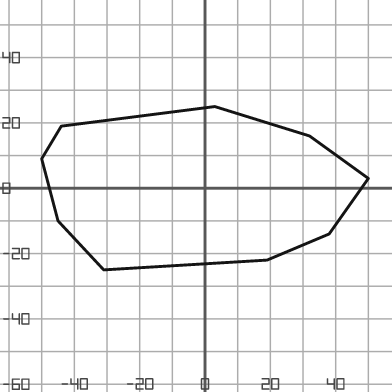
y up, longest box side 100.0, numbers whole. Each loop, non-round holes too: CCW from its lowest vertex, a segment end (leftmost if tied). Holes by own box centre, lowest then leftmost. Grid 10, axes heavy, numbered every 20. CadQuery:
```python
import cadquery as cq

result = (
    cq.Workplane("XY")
    .moveTo(-31.0, -25.0)
    .lineTo(19.0, -22.0)
    .lineTo(38.0, -14.0)
    .lineTo(50.0, 3.0)
    .lineTo(32.0, 16.0)
    .lineTo(3.0, 25.0)
    .lineTo(-44.0, 19.0)
    .lineTo(-50.0, 9.0)
    .lineTo(-45.0, -10.0)
    .close()
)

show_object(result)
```